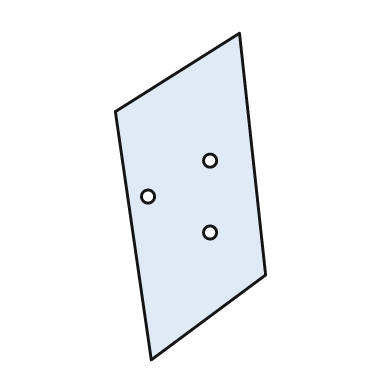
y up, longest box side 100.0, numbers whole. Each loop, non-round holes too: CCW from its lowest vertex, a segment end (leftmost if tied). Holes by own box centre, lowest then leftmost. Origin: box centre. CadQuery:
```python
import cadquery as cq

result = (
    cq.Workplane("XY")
    .moveTo(-12.0, -50.0)
    .lineTo(23.0, -24.0)
    .lineTo(15.0, 50.0)
    .lineTo(-23.0, 26.0)
    .close()
    .moveTo(6.0, -11.0)
    .circle(2.0)
    .moveTo(-13.0, 0.0)
    .circle(2.0)
    .moveTo(6.0, 11.0)
    .circle(2.0)
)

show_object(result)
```